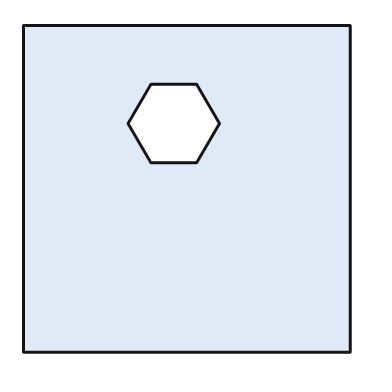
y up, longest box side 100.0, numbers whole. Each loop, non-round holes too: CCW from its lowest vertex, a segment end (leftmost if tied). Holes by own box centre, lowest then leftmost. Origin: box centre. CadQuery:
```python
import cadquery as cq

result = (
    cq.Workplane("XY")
    .moveTo(-50.0, -50.0)
    .lineTo(50.0, -50.0)
    .lineTo(50.0, 50.0)
    .lineTo(-50.0, 50.0)
    .close()
    .moveTo(-11.0, 8.0)
    .lineTo(3.0, 8.0)
    .lineTo(10.0, 20.0)
    .lineTo(3.0, 32.0)
    .lineTo(-11.0, 32.0)
    .lineTo(-18.0, 20.0)
    .close()
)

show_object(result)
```